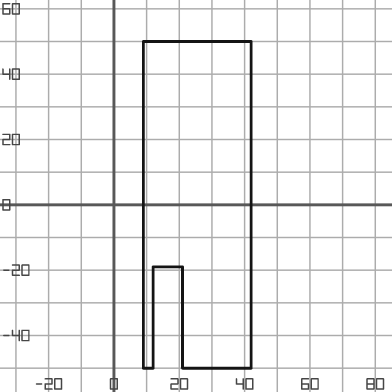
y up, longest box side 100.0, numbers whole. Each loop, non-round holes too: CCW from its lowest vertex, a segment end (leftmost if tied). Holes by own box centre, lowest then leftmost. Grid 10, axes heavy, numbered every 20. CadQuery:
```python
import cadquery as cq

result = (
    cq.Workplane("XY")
    .moveTo(9.0, -50.0)
    .lineTo(12.0, -50.0)
    .lineTo(12.0, -19.0)
    .lineTo(21.0, -19.0)
    .lineTo(21.0, -50.0)
    .lineTo(42.0, -50.0)
    .lineTo(42.0, 50.0)
    .lineTo(9.0, 50.0)
    .close()
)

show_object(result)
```